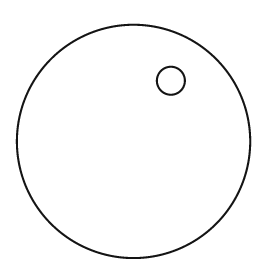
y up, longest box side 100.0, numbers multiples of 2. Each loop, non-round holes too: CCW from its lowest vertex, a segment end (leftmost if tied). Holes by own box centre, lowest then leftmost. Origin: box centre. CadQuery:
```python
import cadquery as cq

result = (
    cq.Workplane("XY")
    .moveTo(0.0, 0.0)
    .circle(50.0)
    .moveTo(16.0, 26.0)
    .circle(6.0)
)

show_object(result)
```